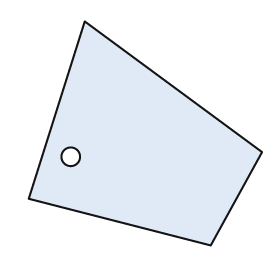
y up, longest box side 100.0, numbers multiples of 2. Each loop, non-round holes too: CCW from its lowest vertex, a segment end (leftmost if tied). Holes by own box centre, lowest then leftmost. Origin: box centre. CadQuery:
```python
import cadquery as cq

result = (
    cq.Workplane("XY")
    .moveTo(28.0, -48.0)
    .lineTo(50.0, -8.0)
    .lineTo(-26.0, 48.0)
    .lineTo(-50.0, -28.0)
    .close()
    .moveTo(-32.0, -10.0)
    .circle(4.0)
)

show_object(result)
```